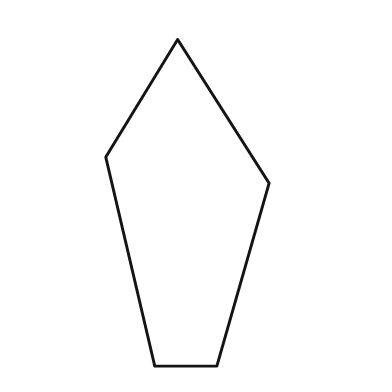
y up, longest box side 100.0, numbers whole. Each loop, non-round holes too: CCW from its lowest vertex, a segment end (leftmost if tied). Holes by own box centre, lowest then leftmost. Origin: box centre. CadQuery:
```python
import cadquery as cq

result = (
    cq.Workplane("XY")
    .moveTo(-10.0, -50.0)
    .lineTo(9.0, -50.0)
    .lineTo(25.0, 6.0)
    .lineTo(-3.0, 50.0)
    .lineTo(-25.0, 14.0)
    .close()
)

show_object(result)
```